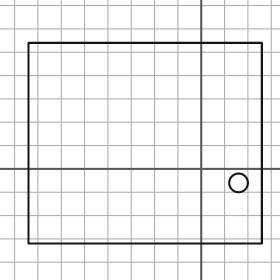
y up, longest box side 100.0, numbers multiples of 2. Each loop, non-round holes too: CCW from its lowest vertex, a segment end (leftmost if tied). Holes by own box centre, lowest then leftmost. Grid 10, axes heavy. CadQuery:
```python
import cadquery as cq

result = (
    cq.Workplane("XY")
    .moveTo(-74.0, -32.0)
    .lineTo(26.0, -32.0)
    .lineTo(26.0, 54.0)
    .lineTo(-74.0, 54.0)
    .close()
    .moveTo(16.0, -6.0)
    .circle(4.0)
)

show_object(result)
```